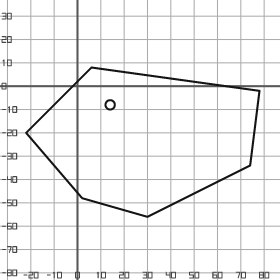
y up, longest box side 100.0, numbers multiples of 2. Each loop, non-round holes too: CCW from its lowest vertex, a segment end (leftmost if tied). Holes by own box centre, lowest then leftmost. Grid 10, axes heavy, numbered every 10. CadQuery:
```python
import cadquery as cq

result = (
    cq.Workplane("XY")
    .moveTo(30.0, -56.0)
    .lineTo(74.0, -34.0)
    .lineTo(78.0, -2.0)
    .lineTo(6.0, 8.0)
    .lineTo(-22.0, -20.0)
    .lineTo(2.0, -48.0)
    .close()
    .moveTo(14.0, -8.0)
    .circle(2.0)
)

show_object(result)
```